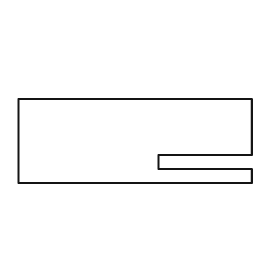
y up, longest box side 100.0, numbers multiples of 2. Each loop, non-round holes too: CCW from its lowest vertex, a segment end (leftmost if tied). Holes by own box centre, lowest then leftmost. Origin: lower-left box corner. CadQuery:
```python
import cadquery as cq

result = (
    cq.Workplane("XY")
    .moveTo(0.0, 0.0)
    .lineTo(100.0, 0.0)
    .lineTo(100.0, 6.0)
    .lineTo(60.0, 6.0)
    .lineTo(60.0, 12.0)
    .lineTo(100.0, 12.0)
    .lineTo(100.0, 36.0)
    .lineTo(0.0, 36.0)
    .close()
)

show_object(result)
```